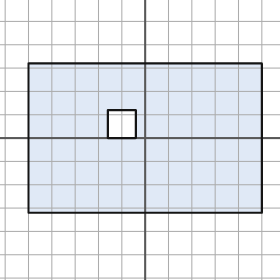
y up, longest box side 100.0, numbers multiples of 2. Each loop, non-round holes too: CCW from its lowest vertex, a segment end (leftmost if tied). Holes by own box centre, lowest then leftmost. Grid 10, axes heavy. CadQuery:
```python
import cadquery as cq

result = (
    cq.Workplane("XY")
    .moveTo(-50.0, -32.0)
    .lineTo(50.0, -32.0)
    .lineTo(50.0, 32.0)
    .lineTo(-50.0, 32.0)
    .close()
    .moveTo(-16.0, 0.0)
    .lineTo(-4.0, 0.0)
    .lineTo(-4.0, 12.0)
    .lineTo(-16.0, 12.0)
    .close()
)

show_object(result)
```